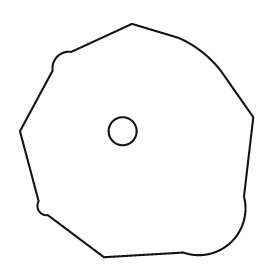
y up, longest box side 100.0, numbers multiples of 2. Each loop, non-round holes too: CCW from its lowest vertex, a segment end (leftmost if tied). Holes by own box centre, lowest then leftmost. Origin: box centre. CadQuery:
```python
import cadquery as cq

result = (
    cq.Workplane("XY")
    .moveTo(-14.0, -50.0)
    .lineTo(20.0, -48.0)
    .threePointArc((40.0, -44.0), (46.0, -24.0))
    .lineTo(50.0, 10.0)
    .lineTo(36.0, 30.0)
    .threePointArc((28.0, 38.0), (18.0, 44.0))
    .lineTo(-2.0, 50.0)
    .lineTo(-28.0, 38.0)
    .threePointArc((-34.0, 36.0), (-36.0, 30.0))
    .lineTo(-50.0, 4.0)
    .lineTo(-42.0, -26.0)
    .threePointArc((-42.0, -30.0), (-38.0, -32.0))
    .close()
    .moveTo(-6.0, 4.0)
    .circle(6.0)
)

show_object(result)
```